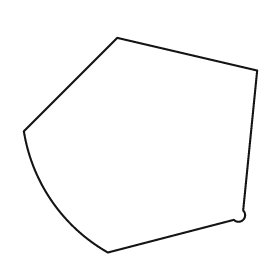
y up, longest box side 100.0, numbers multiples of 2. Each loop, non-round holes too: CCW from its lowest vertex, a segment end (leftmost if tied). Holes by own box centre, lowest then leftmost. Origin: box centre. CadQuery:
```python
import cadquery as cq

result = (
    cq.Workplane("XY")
    .moveTo(-14.0, -46.0)
    .lineTo(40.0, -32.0)
    .threePointArc((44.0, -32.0), (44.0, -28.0))
    .lineTo(50.0, 32.0)
    .lineTo(-10.0, 46.0)
    .lineTo(-50.0, 6.0)
    .threePointArc((-38.0, -24.0), (-14.0, -46.0))
    .close()
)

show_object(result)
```